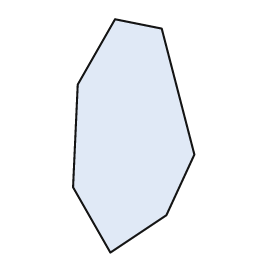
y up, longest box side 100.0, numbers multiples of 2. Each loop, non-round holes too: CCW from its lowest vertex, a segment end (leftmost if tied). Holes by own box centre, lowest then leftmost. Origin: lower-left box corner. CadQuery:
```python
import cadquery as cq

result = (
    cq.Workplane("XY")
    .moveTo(16.0, 0.0)
    .lineTo(40.0, 16.0)
    .lineTo(52.0, 42.0)
    .lineTo(38.0, 96.0)
    .lineTo(18.0, 100.0)
    .lineTo(2.0, 72.0)
    .lineTo(0.0, 28.0)
    .close()
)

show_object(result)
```